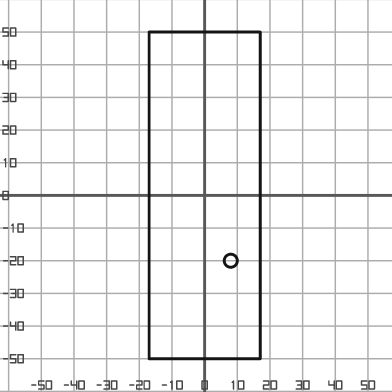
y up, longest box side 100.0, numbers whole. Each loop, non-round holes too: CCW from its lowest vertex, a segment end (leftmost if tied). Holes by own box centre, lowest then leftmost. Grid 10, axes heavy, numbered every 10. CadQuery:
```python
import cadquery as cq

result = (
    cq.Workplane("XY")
    .moveTo(-17.0, -50.0)
    .lineTo(17.0, -50.0)
    .lineTo(17.0, 50.0)
    .lineTo(-17.0, 50.0)
    .close()
    .moveTo(8.0, -20.0)
    .circle(2.0)
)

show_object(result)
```